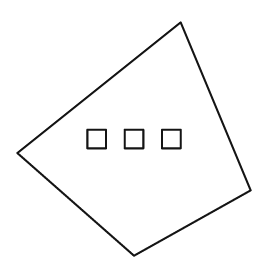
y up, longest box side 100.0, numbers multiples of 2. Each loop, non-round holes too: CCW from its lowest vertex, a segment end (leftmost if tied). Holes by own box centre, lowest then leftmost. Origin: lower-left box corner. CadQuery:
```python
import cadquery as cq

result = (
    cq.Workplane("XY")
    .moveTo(50.0, 0.0)
    .lineTo(100.0, 28.0)
    .lineTo(70.0, 100.0)
    .lineTo(0.0, 44.0)
    .close()
    .moveTo(30.0, 46.0)
    .lineTo(38.0, 46.0)
    .lineTo(38.0, 54.0)
    .lineTo(30.0, 54.0)
    .close()
    .moveTo(46.0, 46.0)
    .lineTo(54.0, 46.0)
    .lineTo(54.0, 54.0)
    .lineTo(46.0, 54.0)
    .close()
    .moveTo(62.0, 46.0)
    .lineTo(70.0, 46.0)
    .lineTo(70.0, 54.0)
    .lineTo(62.0, 54.0)
    .close()
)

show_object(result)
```